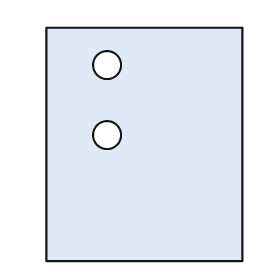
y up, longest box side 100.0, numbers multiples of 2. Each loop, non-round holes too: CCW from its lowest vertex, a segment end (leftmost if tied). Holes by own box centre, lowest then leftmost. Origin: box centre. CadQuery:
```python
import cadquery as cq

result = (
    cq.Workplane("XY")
    .moveTo(-42.0, -50.0)
    .lineTo(42.0, -50.0)
    .lineTo(42.0, 50.0)
    .lineTo(-42.0, 50.0)
    .close()
    .moveTo(-16.0, 4.0)
    .circle(6.0)
    .moveTo(-16.0, 34.0)
    .circle(6.0)
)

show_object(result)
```